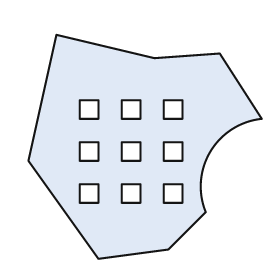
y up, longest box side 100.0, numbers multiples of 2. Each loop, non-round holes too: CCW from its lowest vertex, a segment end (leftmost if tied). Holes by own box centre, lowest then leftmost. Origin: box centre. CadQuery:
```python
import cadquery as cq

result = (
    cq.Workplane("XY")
    .moveTo(-20.0, -48.0)
    .lineTo(10.0, -44.0)
    .lineTo(26.0, -28.0)
    .threePointArc((28.0, -2.0), (50.0, 12.0))
    .lineTo(32.0, 40.0)
    .lineTo(4.0, 38.0)
    .lineTo(-38.0, 48.0)
    .lineTo(-50.0, -6.0)
    .close()
    .moveTo(-28.0, -24.0)
    .lineTo(-20.0, -24.0)
    .lineTo(-20.0, -16.0)
    .lineTo(-28.0, -16.0)
    .close()
    .moveTo(-10.0, -24.0)
    .lineTo(-2.0, -24.0)
    .lineTo(-2.0, -16.0)
    .lineTo(-10.0, -16.0)
    .close()
    .moveTo(8.0, -24.0)
    .lineTo(16.0, -24.0)
    .lineTo(16.0, -16.0)
    .lineTo(8.0, -16.0)
    .close()
    .moveTo(-28.0, -6.0)
    .lineTo(-20.0, -6.0)
    .lineTo(-20.0, 2.0)
    .lineTo(-28.0, 2.0)
    .close()
    .moveTo(-10.0, -6.0)
    .lineTo(-2.0, -6.0)
    .lineTo(-2.0, 2.0)
    .lineTo(-10.0, 2.0)
    .close()
    .moveTo(8.0, -6.0)
    .lineTo(16.0, -6.0)
    .lineTo(16.0, 2.0)
    .lineTo(8.0, 2.0)
    .close()
    .moveTo(-28.0, 12.0)
    .lineTo(-20.0, 12.0)
    .lineTo(-20.0, 20.0)
    .lineTo(-28.0, 20.0)
    .close()
    .moveTo(-10.0, 12.0)
    .lineTo(-2.0, 12.0)
    .lineTo(-2.0, 20.0)
    .lineTo(-10.0, 20.0)
    .close()
    .moveTo(8.0, 12.0)
    .lineTo(16.0, 12.0)
    .lineTo(16.0, 20.0)
    .lineTo(8.0, 20.0)
    .close()
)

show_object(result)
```